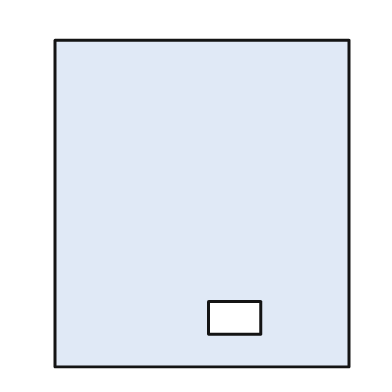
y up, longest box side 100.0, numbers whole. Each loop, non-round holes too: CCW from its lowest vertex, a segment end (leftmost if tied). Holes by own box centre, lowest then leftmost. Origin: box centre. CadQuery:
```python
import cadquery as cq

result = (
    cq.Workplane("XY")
    .moveTo(-45.0, -50.0)
    .lineTo(45.0, -50.0)
    .lineTo(45.0, 50.0)
    .lineTo(-45.0, 50.0)
    .close()
    .moveTo(2.0, -40.0)
    .lineTo(18.0, -40.0)
    .lineTo(18.0, -30.0)
    .lineTo(2.0, -30.0)
    .close()
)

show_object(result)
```